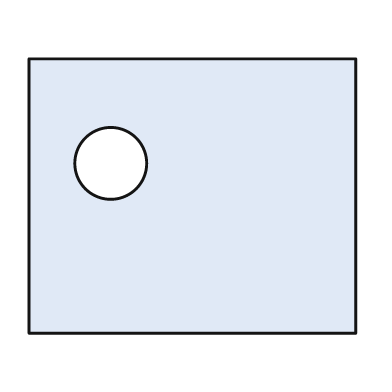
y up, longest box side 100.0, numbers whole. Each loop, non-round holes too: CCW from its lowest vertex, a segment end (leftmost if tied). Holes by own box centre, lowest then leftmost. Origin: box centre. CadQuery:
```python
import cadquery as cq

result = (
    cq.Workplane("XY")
    .moveTo(-50.0, -42.0)
    .lineTo(50.0, -42.0)
    .lineTo(50.0, 42.0)
    .lineTo(-50.0, 42.0)
    .close()
    .moveTo(-25.0, 10.0)
    .circle(11.0)
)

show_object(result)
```